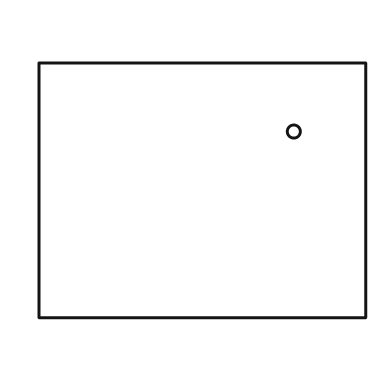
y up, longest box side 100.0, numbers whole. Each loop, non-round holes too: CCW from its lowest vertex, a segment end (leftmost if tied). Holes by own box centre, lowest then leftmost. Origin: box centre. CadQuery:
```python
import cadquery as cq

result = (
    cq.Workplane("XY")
    .moveTo(-50.0, -39.0)
    .lineTo(50.0, -39.0)
    .lineTo(50.0, 39.0)
    .lineTo(-50.0, 39.0)
    .close()
    .moveTo(28.0, 18.0)
    .circle(2.0)
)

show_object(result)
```